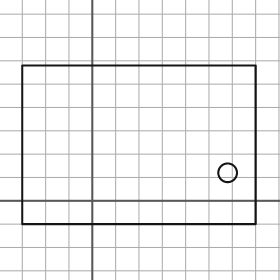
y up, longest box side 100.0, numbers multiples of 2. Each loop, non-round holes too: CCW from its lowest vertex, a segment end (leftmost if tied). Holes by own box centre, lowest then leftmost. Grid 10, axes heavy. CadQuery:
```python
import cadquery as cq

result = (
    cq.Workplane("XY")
    .moveTo(-30.0, -10.0)
    .lineTo(70.0, -10.0)
    .lineTo(70.0, 58.0)
    .lineTo(-30.0, 58.0)
    .close()
    .moveTo(58.0, 12.0)
    .circle(4.0)
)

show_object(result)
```